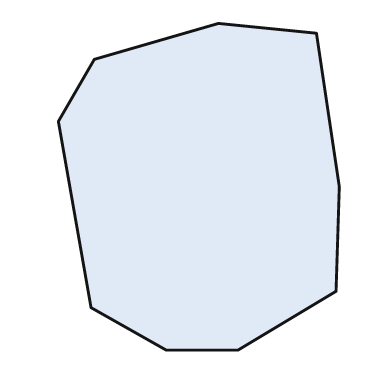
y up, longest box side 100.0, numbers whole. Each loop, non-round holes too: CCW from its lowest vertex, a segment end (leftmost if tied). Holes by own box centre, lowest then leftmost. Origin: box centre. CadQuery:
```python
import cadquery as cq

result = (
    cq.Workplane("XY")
    .moveTo(-10.0, -50.0)
    .lineTo(12.0, -50.0)
    .lineTo(42.0, -32.0)
    .lineTo(43.0, 0.0)
    .lineTo(36.0, 47.0)
    .lineTo(6.0, 50.0)
    .lineTo(-32.0, 39.0)
    .lineTo(-43.0, 20.0)
    .lineTo(-33.0, -37.0)
    .close()
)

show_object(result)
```